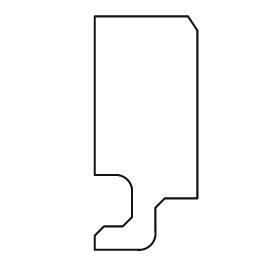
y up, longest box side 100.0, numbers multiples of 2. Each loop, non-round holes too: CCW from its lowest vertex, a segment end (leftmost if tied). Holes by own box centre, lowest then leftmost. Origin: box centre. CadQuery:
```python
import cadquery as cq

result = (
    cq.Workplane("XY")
    .moveTo(-22.0, -50.0)
    .lineTo(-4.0, -50.0)
    .threePointArc((2.0, -48.0), (4.0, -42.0))
    .lineTo(4.0, -32.0)
    .lineTo(8.0, -28.0)
    .lineTo(22.0, -28.0)
    .lineTo(22.0, 44.0)
    .lineTo(18.0, 50.0)
    .lineTo(-22.0, 50.0)
    .lineTo(-22.0, -18.0)
    .lineTo(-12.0, -18.0)
    .threePointArc((-8.0, -20.0), (-6.0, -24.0))
    .lineTo(-6.0, -36.0)
    .lineTo(-10.0, -40.0)
    .lineTo(-18.0, -40.0)
    .lineTo(-22.0, -44.0)
    .close()
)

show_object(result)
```